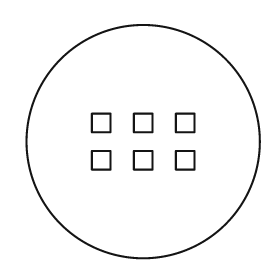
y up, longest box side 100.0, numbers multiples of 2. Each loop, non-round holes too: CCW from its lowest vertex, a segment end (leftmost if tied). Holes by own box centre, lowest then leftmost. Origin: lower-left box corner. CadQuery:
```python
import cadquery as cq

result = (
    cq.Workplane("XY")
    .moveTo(50.0, 50.0)
    .circle(50.0)
    .moveTo(28.0, 38.0)
    .lineTo(36.0, 38.0)
    .lineTo(36.0, 46.0)
    .lineTo(28.0, 46.0)
    .close()
    .moveTo(46.0, 38.0)
    .lineTo(54.0, 38.0)
    .lineTo(54.0, 46.0)
    .lineTo(46.0, 46.0)
    .close()
    .moveTo(64.0, 38.0)
    .lineTo(72.0, 38.0)
    .lineTo(72.0, 46.0)
    .lineTo(64.0, 46.0)
    .close()
    .moveTo(28.0, 54.0)
    .lineTo(36.0, 54.0)
    .lineTo(36.0, 62.0)
    .lineTo(28.0, 62.0)
    .close()
    .moveTo(46.0, 54.0)
    .lineTo(54.0, 54.0)
    .lineTo(54.0, 62.0)
    .lineTo(46.0, 62.0)
    .close()
    .moveTo(64.0, 54.0)
    .lineTo(72.0, 54.0)
    .lineTo(72.0, 62.0)
    .lineTo(64.0, 62.0)
    .close()
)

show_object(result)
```